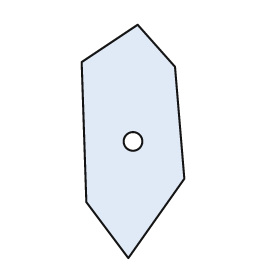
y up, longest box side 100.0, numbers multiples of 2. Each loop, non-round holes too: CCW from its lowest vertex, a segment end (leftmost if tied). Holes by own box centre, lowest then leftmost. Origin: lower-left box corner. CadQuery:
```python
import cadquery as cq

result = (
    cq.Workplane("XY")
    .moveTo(20.0, 0.0)
    .lineTo(44.0, 34.0)
    .lineTo(40.0, 82.0)
    .lineTo(24.0, 100.0)
    .lineTo(0.0, 84.0)
    .lineTo(2.0, 24.0)
    .close()
    .moveTo(22.0, 50.0)
    .circle(4.0)
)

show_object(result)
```